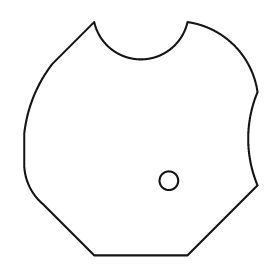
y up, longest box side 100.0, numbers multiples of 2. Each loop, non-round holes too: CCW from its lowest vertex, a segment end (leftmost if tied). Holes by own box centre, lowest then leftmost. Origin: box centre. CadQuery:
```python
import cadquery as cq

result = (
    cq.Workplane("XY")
    .moveTo(-20.0, -50.0)
    .lineTo(20.0, -50.0)
    .lineTo(50.0, -20.0)
    .threePointArc((46.0, 0.0), (50.0, 20.0))
    .threePointArc((40.0, 40.0), (20.0, 50.0))
    .threePointArc((0.0, 34.0), (-20.0, 50.0))
    .lineTo(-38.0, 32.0)
    .threePointArc((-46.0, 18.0), (-50.0, 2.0))
    .lineTo(-50.0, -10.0)
    .threePointArc((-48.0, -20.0), (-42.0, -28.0))
    .close()
    .moveTo(12.0, -18.0)
    .circle(4.0)
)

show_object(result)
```